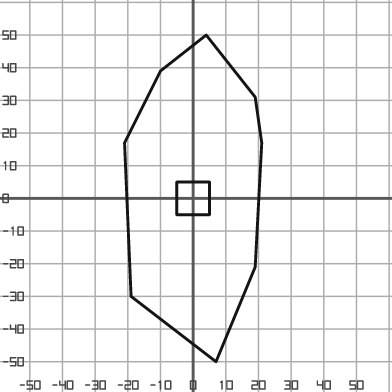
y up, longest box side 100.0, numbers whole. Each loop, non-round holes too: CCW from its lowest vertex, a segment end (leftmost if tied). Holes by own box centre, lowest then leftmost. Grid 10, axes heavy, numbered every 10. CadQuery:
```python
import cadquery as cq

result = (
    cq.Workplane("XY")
    .moveTo(7.0, -50.0)
    .lineTo(19.0, -21.0)
    .lineTo(21.0, 17.0)
    .lineTo(19.0, 31.0)
    .lineTo(4.0, 50.0)
    .lineTo(-10.0, 39.0)
    .lineTo(-21.0, 17.0)
    .lineTo(-19.0, -30.0)
    .close()
    .moveTo(-5.0, -5.0)
    .lineTo(5.0, -5.0)
    .lineTo(5.0, 5.0)
    .lineTo(-5.0, 5.0)
    .close()
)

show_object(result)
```